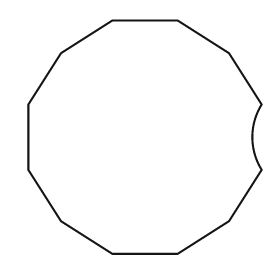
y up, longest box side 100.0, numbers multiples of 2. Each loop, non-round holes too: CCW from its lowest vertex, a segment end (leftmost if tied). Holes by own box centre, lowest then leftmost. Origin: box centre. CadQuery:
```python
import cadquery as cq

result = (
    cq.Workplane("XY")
    .moveTo(-14.0, -50.0)
    .lineTo(14.0, -50.0)
    .lineTo(36.0, -36.0)
    .lineTo(50.0, -14.0)
    .threePointArc((46.0, 0.0), (50.0, 14.0))
    .lineTo(36.0, 36.0)
    .lineTo(14.0, 50.0)
    .lineTo(-14.0, 50.0)
    .lineTo(-36.0, 36.0)
    .lineTo(-50.0, 14.0)
    .lineTo(-50.0, -14.0)
    .lineTo(-36.0, -36.0)
    .close()
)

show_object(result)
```